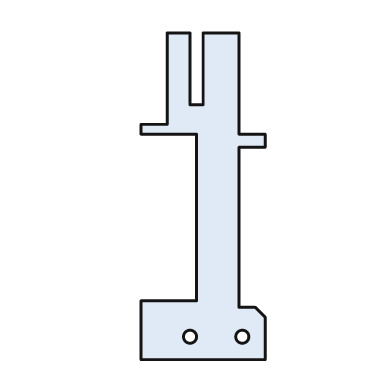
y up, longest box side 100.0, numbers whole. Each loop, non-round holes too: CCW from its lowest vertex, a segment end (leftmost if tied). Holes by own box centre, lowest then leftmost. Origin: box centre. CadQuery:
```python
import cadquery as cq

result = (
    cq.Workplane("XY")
    .moveTo(-19.0, -50.0)
    .lineTo(19.0, -50.0)
    .lineTo(19.0, -37.0)
    .lineTo(16.0, -34.0)
    .lineTo(11.0, -34.0)
    .lineTo(11.0, 15.0)
    .lineTo(19.0, 15.0)
    .lineTo(19.0, 19.0)
    .lineTo(11.0, 19.0)
    .lineTo(11.0, 50.0)
    .lineTo(0.0, 50.0)
    .lineTo(0.0, 28.0)
    .lineTo(-4.0, 28.0)
    .lineTo(-4.0, 50.0)
    .lineTo(-11.0, 50.0)
    .lineTo(-11.0, 22.0)
    .lineTo(-19.0, 22.0)
    .lineTo(-19.0, 19.0)
    .lineTo(-2.0, 19.0)
    .lineTo(-2.0, -32.0)
    .lineTo(-19.0, -32.0)
    .close()
    .moveTo(-4.0, -43.0)
    .circle(2.0)
    .moveTo(12.0, -43.0)
    .circle(2.0)
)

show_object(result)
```